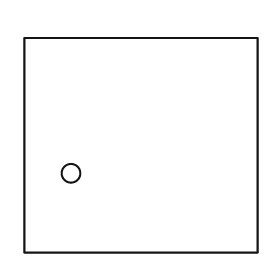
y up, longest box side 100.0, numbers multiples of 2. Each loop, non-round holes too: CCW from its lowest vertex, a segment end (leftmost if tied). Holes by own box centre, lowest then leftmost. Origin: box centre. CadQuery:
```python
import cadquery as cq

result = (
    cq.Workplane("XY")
    .moveTo(-50.0, -46.0)
    .lineTo(50.0, -46.0)
    .lineTo(50.0, 46.0)
    .lineTo(-50.0, 46.0)
    .close()
    .moveTo(-30.0, -12.0)
    .circle(4.0)
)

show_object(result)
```